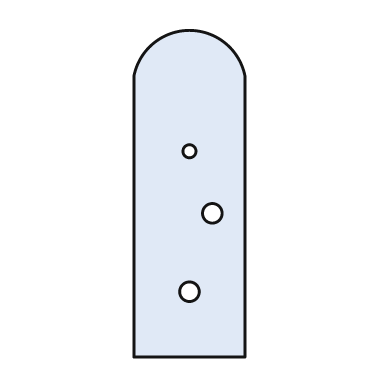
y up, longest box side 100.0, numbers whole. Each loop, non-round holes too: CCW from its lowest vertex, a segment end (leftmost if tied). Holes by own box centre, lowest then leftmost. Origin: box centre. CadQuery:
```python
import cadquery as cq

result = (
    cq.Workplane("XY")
    .moveTo(-17.0, -50.0)
    .lineTo(17.0, -50.0)
    .lineTo(17.0, 36.0)
    .threePointArc((0.0, 50.0), (-17.0, 36.0))
    .close()
    .moveTo(0.0, -30.0)
    .circle(3.0)
    .moveTo(7.0, -6.0)
    .circle(3.0)
    .moveTo(0.0, 13.0)
    .circle(2.0)
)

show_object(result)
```